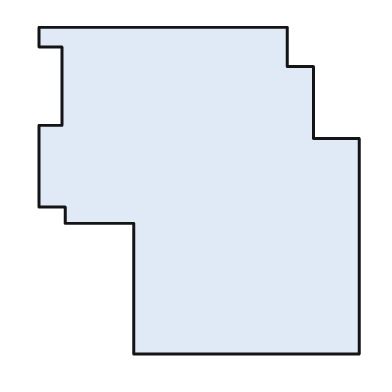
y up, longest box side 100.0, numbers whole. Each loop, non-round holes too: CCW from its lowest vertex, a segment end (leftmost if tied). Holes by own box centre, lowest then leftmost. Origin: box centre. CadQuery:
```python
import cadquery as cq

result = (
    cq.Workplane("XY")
    .moveTo(-20.0, -50.0)
    .lineTo(49.0, -50.0)
    .lineTo(49.0, 16.0)
    .lineTo(35.0, 16.0)
    .lineTo(35.0, 38.0)
    .lineTo(27.0, 38.0)
    .lineTo(27.0, 50.0)
    .lineTo(-49.0, 50.0)
    .lineTo(-49.0, 44.0)
    .lineTo(-42.0, 44.0)
    .lineTo(-42.0, 20.0)
    .lineTo(-49.0, 20.0)
    .lineTo(-49.0, -5.0)
    .lineTo(-41.0, -5.0)
    .lineTo(-41.0, -10.0)
    .lineTo(-20.0, -10.0)
    .close()
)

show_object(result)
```